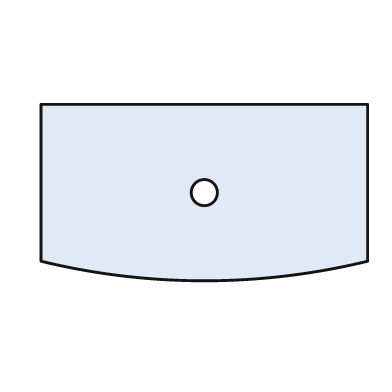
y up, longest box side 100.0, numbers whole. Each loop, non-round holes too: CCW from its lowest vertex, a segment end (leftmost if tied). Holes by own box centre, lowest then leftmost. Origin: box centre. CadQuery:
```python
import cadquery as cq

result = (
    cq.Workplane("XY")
    .moveTo(-50.0, -21.0)
    .threePointArc((0.0, -27.0), (50.0, -21.0))
    .lineTo(50.0, 27.0)
    .lineTo(-50.0, 27.0)
    .close()
    .moveTo(0.0, 0.0)
    .circle(4.0)
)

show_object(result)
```